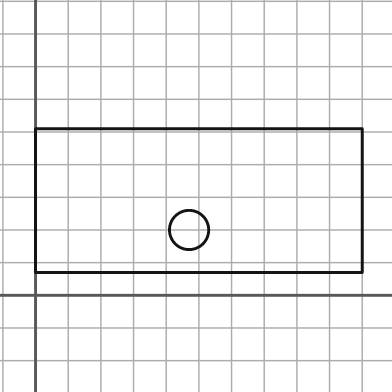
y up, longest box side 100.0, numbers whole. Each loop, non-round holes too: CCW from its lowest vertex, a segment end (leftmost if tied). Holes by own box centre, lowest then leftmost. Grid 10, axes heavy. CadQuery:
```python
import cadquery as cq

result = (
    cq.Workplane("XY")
    .moveTo(0.0, 7.0)
    .lineTo(100.0, 7.0)
    .lineTo(100.0, 51.0)
    .lineTo(0.0, 51.0)
    .close()
    .moveTo(47.0, 20.0)
    .circle(6.0)
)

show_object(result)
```